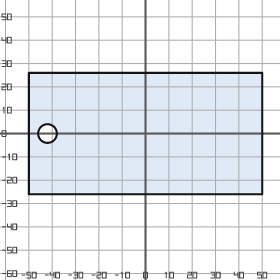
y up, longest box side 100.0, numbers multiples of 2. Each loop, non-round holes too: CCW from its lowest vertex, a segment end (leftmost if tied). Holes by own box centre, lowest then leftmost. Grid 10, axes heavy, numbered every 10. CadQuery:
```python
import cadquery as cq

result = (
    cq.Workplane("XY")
    .moveTo(-50.0, -26.0)
    .lineTo(50.0, -26.0)
    .lineTo(50.0, 26.0)
    .lineTo(-50.0, 26.0)
    .close()
    .moveTo(-42.0, 0.0)
    .circle(4.0)
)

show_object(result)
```